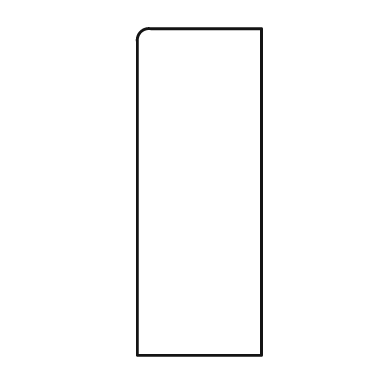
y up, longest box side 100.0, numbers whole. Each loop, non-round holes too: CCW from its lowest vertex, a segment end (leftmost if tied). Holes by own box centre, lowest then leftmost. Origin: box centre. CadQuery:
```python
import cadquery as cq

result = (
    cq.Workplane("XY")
    .moveTo(-19.0, -50.0)
    .lineTo(19.0, -50.0)
    .lineTo(19.0, 50.0)
    .lineTo(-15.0, 50.0)
    .threePointArc((-18.0, 49.0), (-19.0, 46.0))
    .close()
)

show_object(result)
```